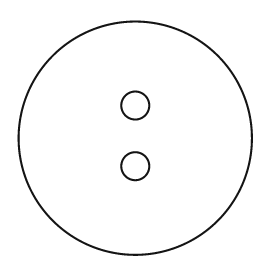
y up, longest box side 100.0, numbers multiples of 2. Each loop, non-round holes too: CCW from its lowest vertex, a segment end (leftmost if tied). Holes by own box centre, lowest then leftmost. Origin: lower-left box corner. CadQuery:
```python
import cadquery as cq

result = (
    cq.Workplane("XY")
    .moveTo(50.0, 50.0)
    .circle(50.0)
    .moveTo(50.0, 38.0)
    .circle(6.0)
    .moveTo(50.0, 64.0)
    .circle(6.0)
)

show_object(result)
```